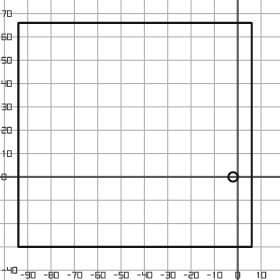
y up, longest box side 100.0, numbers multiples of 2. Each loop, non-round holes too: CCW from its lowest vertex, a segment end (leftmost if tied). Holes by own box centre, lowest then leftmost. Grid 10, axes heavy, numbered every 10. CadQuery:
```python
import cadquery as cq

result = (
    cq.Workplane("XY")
    .moveTo(-94.0, -30.0)
    .lineTo(6.0, -30.0)
    .lineTo(6.0, 66.0)
    .lineTo(-94.0, 66.0)
    .close()
    .moveTo(-2.0, 0.0)
    .circle(2.0)
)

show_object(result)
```